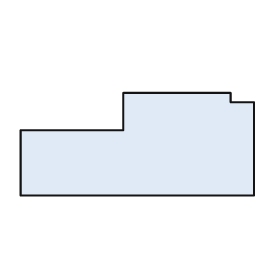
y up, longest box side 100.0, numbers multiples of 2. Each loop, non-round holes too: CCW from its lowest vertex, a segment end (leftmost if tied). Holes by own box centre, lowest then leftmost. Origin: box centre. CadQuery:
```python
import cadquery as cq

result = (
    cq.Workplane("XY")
    .moveTo(-50.0, -22.0)
    .lineTo(50.0, -22.0)
    .lineTo(50.0, 18.0)
    .lineTo(40.0, 18.0)
    .lineTo(40.0, 22.0)
    .lineTo(-6.0, 22.0)
    .lineTo(-6.0, 6.0)
    .lineTo(-50.0, 6.0)
    .close()
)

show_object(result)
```